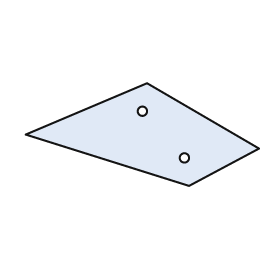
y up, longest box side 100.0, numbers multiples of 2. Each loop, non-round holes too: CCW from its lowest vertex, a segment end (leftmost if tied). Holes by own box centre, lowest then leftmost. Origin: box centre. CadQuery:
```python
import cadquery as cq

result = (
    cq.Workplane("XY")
    .moveTo(20.0, -22.0)
    .lineTo(50.0, -6.0)
    .lineTo(2.0, 22.0)
    .lineTo(-50.0, 0.0)
    .close()
    .moveTo(18.0, -10.0)
    .circle(2.0)
    .moveTo(0.0, 10.0)
    .circle(2.0)
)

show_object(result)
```